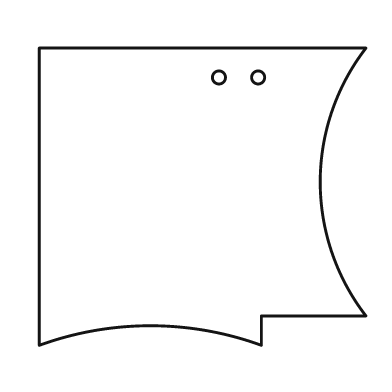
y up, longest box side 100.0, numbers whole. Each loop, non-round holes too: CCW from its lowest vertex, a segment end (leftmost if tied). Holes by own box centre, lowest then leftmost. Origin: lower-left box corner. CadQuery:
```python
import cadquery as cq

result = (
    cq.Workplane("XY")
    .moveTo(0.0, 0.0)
    .threePointArc((34.0, 6.0), (68.0, 0.0))
    .lineTo(68.0, 9.0)
    .lineTo(100.0, 9.0)
    .threePointArc((86.0, 50.0), (100.0, 91.0))
    .lineTo(0.0, 91.0)
    .close()
    .moveTo(55.0, 82.0)
    .circle(2.0)
    .moveTo(67.0, 82.0)
    .circle(2.0)
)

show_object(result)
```